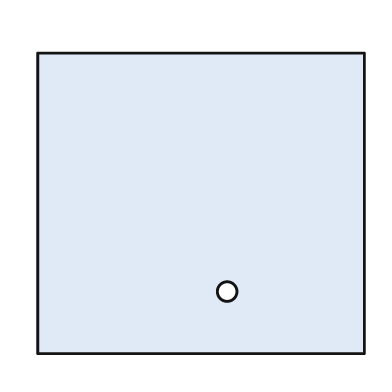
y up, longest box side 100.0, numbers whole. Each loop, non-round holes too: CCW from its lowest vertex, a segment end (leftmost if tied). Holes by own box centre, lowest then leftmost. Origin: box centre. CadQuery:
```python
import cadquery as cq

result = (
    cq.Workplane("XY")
    .moveTo(-50.0, -46.0)
    .lineTo(50.0, -46.0)
    .lineTo(50.0, 46.0)
    .lineTo(-50.0, 46.0)
    .close()
    .moveTo(8.0, -27.0)
    .circle(3.0)
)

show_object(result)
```